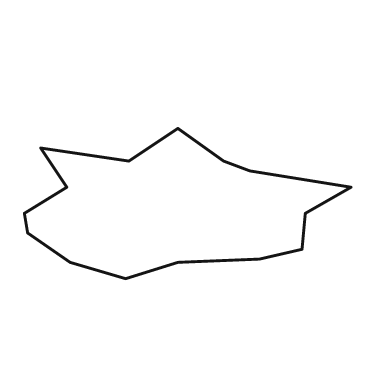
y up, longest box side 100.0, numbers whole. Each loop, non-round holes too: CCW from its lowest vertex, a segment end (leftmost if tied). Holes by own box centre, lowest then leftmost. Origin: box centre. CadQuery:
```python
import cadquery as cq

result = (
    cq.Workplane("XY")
    .moveTo(-19.0, -23.0)
    .lineTo(-3.0, -18.0)
    .lineTo(22.0, -17.0)
    .lineTo(35.0, -14.0)
    .lineTo(36.0, -3.0)
    .lineTo(50.0, 5.0)
    .lineTo(19.0, 10.0)
    .lineTo(11.0, 13.0)
    .lineTo(-3.0, 23.0)
    .lineTo(-18.0, 13.0)
    .lineTo(-45.0, 17.0)
    .lineTo(-37.0, 5.0)
    .lineTo(-50.0, -3.0)
    .lineTo(-49.0, -9.0)
    .lineTo(-36.0, -18.0)
    .close()
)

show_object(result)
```